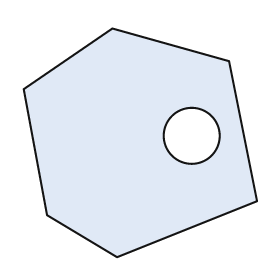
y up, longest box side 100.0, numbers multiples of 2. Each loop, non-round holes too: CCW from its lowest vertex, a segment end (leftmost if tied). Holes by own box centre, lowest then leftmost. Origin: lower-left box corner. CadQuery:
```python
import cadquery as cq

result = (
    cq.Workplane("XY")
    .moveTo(40.0, 0.0)
    .lineTo(100.0, 24.0)
    .lineTo(88.0, 84.0)
    .lineTo(38.0, 98.0)
    .lineTo(0.0, 72.0)
    .lineTo(10.0, 18.0)
    .close()
    .moveTo(72.0, 52.0)
    .circle(12.0)
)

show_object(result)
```